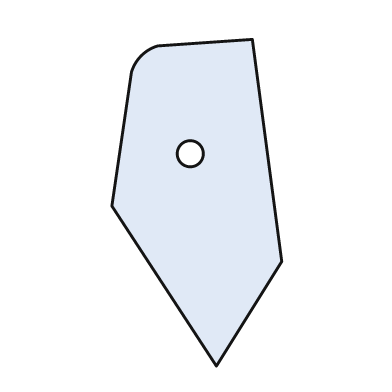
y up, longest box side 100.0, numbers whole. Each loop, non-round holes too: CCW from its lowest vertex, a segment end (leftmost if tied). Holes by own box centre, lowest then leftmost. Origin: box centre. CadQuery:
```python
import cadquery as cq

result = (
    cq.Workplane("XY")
    .moveTo(6.0, -50.0)
    .lineTo(26.0, -18.0)
    .lineTo(17.0, 50.0)
    .lineTo(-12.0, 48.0)
    .threePointArc((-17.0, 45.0), (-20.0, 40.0))
    .lineTo(-26.0, -1.0)
    .close()
    .moveTo(-2.0, 15.0)
    .circle(4.0)
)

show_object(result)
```